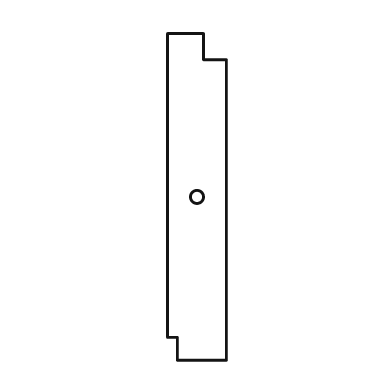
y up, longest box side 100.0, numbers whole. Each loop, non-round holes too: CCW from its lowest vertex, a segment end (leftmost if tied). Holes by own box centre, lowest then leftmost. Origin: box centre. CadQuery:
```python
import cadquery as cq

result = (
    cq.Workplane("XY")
    .moveTo(-6.0, -50.0)
    .lineTo(9.0, -50.0)
    .lineTo(9.0, 42.0)
    .lineTo(2.0, 42.0)
    .lineTo(2.0, 50.0)
    .lineTo(-9.0, 50.0)
    .lineTo(-9.0, -43.0)
    .lineTo(-6.0, -43.0)
    .close()
    .moveTo(0.0, 0.0)
    .circle(2.0)
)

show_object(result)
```